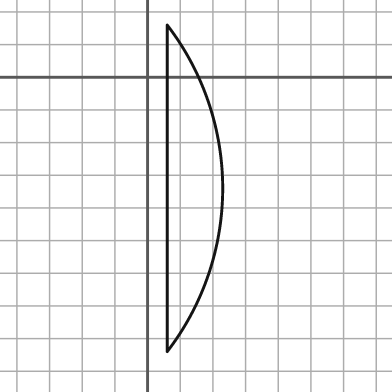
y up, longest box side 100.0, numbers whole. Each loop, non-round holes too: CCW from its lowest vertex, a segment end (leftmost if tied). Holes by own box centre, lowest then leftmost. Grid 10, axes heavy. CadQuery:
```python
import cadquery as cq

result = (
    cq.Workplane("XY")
    .moveTo(6.0, -84.0)
    .threePointArc((23.0, -34.0), (6.0, 16.0))
    .close()
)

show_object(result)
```